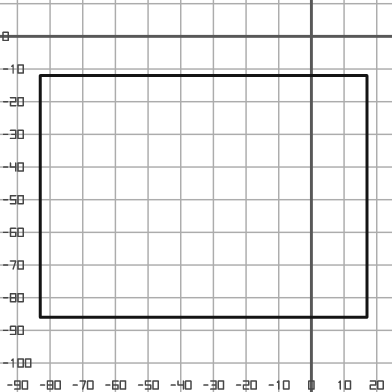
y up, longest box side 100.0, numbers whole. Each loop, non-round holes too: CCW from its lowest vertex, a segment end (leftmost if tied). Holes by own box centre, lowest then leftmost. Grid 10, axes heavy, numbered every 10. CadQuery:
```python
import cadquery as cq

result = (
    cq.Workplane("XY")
    .moveTo(-83.0, -86.0)
    .lineTo(17.0, -86.0)
    .lineTo(17.0, -12.0)
    .lineTo(-83.0, -12.0)
    .close()
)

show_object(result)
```